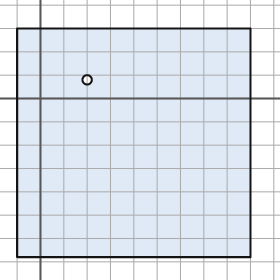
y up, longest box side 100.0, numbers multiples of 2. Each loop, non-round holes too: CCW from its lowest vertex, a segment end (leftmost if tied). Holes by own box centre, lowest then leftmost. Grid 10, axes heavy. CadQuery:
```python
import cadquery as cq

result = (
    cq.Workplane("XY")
    .moveTo(-10.0, -68.0)
    .lineTo(90.0, -68.0)
    .lineTo(90.0, 30.0)
    .lineTo(-10.0, 30.0)
    .close()
    .moveTo(20.0, 8.0)
    .circle(2.0)
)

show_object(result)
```